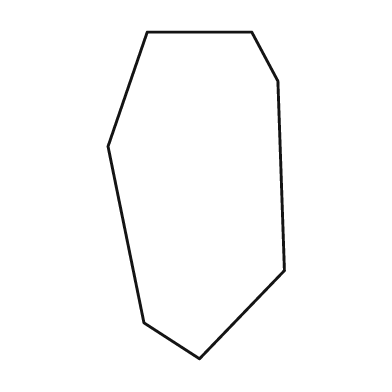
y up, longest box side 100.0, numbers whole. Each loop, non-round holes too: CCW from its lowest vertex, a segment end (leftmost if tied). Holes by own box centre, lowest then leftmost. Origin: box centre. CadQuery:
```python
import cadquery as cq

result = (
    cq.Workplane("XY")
    .moveTo(1.0, -50.0)
    .lineTo(27.0, -23.0)
    .lineTo(25.0, 35.0)
    .lineTo(17.0, 50.0)
    .lineTo(-15.0, 50.0)
    .lineTo(-27.0, 15.0)
    .lineTo(-16.0, -39.0)
    .close()
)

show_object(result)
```